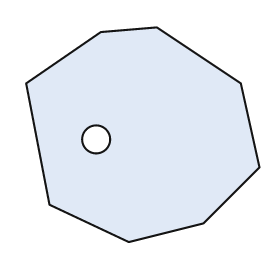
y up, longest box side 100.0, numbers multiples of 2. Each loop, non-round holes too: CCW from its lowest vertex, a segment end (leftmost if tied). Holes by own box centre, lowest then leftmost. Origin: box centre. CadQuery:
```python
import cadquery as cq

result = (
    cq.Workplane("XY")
    .moveTo(-6.0, -46.0)
    .lineTo(26.0, -38.0)
    .lineTo(50.0, -14.0)
    .lineTo(42.0, 22.0)
    .lineTo(6.0, 46.0)
    .lineTo(-18.0, 44.0)
    .lineTo(-50.0, 22.0)
    .lineTo(-40.0, -30.0)
    .close()
    .moveTo(-20.0, -2.0)
    .circle(6.0)
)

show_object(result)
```